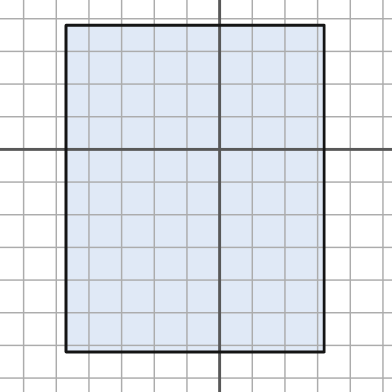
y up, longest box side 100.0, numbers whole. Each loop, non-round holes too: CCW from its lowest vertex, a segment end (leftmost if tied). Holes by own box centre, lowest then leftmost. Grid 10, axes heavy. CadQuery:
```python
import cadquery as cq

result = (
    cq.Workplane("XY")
    .moveTo(-47.0, -62.0)
    .lineTo(32.0, -62.0)
    .lineTo(32.0, 38.0)
    .lineTo(-47.0, 38.0)
    .close()
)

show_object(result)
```